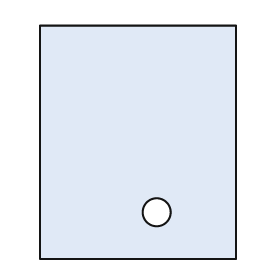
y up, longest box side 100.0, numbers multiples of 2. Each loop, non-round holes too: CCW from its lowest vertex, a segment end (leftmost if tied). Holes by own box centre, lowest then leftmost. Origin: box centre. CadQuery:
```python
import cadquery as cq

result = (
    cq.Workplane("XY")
    .moveTo(-42.0, -50.0)
    .lineTo(42.0, -50.0)
    .lineTo(42.0, 50.0)
    .lineTo(-42.0, 50.0)
    .close()
    .moveTo(8.0, -30.0)
    .circle(6.0)
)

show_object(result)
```